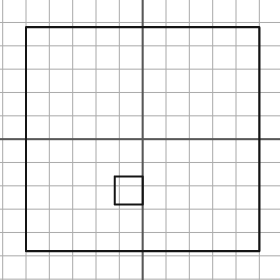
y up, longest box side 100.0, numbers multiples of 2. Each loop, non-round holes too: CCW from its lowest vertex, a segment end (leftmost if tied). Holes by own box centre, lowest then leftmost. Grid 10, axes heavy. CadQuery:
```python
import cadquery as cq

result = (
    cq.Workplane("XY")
    .moveTo(-50.0, -48.0)
    .lineTo(50.0, -48.0)
    .lineTo(50.0, 48.0)
    .lineTo(-50.0, 48.0)
    .close()
    .moveTo(-12.0, -28.0)
    .lineTo(0.0, -28.0)
    .lineTo(0.0, -16.0)
    .lineTo(-12.0, -16.0)
    .close()
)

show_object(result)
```